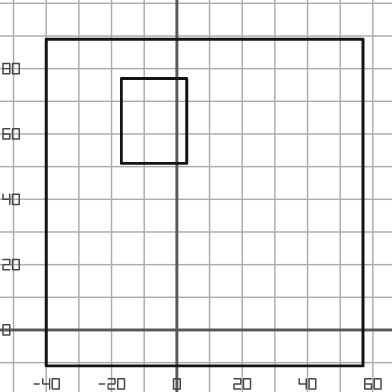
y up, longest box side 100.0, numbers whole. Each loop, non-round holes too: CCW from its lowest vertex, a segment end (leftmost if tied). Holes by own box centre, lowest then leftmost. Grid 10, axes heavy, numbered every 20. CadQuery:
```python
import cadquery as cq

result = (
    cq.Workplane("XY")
    .moveTo(-40.0, -11.0)
    .lineTo(57.0, -11.0)
    .lineTo(57.0, 89.0)
    .lineTo(-40.0, 89.0)
    .close()
    .moveTo(-17.0, 51.0)
    .lineTo(3.0, 51.0)
    .lineTo(3.0, 77.0)
    .lineTo(-17.0, 77.0)
    .close()
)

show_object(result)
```